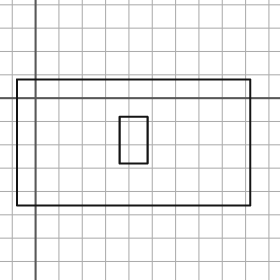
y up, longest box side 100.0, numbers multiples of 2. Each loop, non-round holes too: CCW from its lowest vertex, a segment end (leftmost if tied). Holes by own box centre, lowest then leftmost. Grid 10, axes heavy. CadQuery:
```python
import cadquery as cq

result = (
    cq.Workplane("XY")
    .moveTo(-8.0, -46.0)
    .lineTo(92.0, -46.0)
    .lineTo(92.0, 8.0)
    .lineTo(-8.0, 8.0)
    .close()
    .moveTo(36.0, -28.0)
    .lineTo(48.0, -28.0)
    .lineTo(48.0, -8.0)
    .lineTo(36.0, -8.0)
    .close()
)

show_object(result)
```